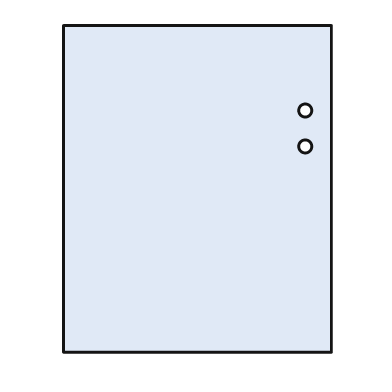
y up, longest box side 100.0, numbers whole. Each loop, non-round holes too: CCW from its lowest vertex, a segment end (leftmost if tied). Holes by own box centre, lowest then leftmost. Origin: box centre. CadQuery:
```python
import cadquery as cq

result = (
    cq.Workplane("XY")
    .moveTo(-41.0, -50.0)
    .lineTo(41.0, -50.0)
    .lineTo(41.0, 50.0)
    .lineTo(-41.0, 50.0)
    .close()
    .moveTo(33.0, 13.0)
    .circle(2.0)
    .moveTo(33.0, 24.0)
    .circle(2.0)
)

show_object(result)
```